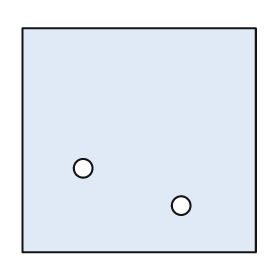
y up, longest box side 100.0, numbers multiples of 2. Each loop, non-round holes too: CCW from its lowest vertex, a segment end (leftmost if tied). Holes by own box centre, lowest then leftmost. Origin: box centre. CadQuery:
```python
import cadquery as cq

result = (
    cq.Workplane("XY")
    .moveTo(-50.0, -48.0)
    .lineTo(50.0, -48.0)
    .lineTo(50.0, 48.0)
    .lineTo(-50.0, 48.0)
    .close()
    .moveTo(18.0, -28.0)
    .circle(4.0)
    .moveTo(-24.0, -12.0)
    .circle(4.0)
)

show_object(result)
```